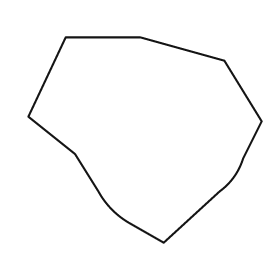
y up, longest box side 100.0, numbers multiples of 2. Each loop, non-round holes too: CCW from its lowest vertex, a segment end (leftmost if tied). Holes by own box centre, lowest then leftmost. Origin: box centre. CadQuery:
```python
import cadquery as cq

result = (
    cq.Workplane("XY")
    .moveTo(8.0, -44.0)
    .lineTo(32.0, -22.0)
    .threePointArc((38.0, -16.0), (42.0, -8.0))
    .lineTo(50.0, 8.0)
    .lineTo(34.0, 34.0)
    .lineTo(-2.0, 44.0)
    .lineTo(-34.0, 44.0)
    .lineTo(-50.0, 10.0)
    .lineTo(-30.0, -6.0)
    .lineTo(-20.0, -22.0)
    .threePointArc((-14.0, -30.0), (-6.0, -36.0))
    .close()
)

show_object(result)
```